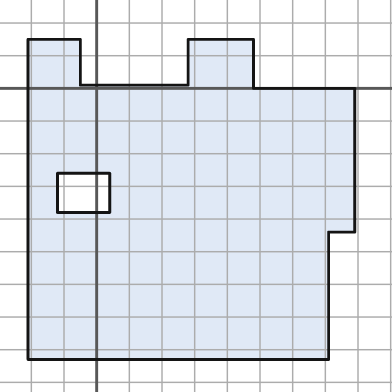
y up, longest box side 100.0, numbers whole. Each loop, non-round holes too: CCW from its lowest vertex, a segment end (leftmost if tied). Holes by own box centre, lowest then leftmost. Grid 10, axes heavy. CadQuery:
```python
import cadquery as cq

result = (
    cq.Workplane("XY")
    .moveTo(-21.0, -83.0)
    .lineTo(71.0, -83.0)
    .lineTo(71.0, -44.0)
    .lineTo(79.0, -44.0)
    .lineTo(79.0, 0.0)
    .lineTo(48.0, 0.0)
    .lineTo(48.0, 15.0)
    .lineTo(28.0, 15.0)
    .lineTo(28.0, 1.0)
    .lineTo(-5.0, 1.0)
    .lineTo(-5.0, 15.0)
    .lineTo(-21.0, 15.0)
    .close()
    .moveTo(-12.0, -38.0)
    .lineTo(4.0, -38.0)
    .lineTo(4.0, -26.0)
    .lineTo(-12.0, -26.0)
    .close()
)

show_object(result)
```